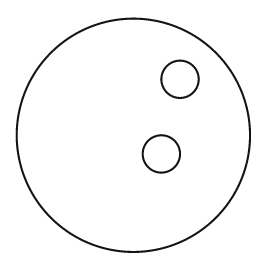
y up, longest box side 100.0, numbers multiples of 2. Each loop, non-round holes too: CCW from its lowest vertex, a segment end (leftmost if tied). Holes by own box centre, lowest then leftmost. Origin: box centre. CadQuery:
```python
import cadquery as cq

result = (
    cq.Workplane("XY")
    .moveTo(0.0, 0.0)
    .circle(50.0)
    .moveTo(12.0, -8.0)
    .circle(8.0)
    .moveTo(20.0, 24.0)
    .circle(8.0)
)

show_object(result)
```